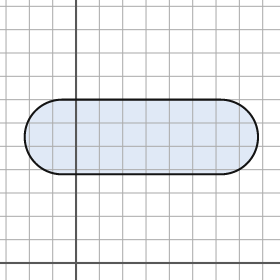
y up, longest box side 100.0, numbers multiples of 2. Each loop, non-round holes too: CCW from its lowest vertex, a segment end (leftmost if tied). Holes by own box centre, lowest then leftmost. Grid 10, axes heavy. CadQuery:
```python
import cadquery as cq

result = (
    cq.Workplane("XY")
    .moveTo(-6.0, 38.0)
    .lineTo(62.0, 38.0)
    .threePointArc((78.0, 54.0), (62.0, 70.0))
    .lineTo(-6.0, 70.0)
    .threePointArc((-22.0, 54.0), (-6.0, 38.0))
    .close()
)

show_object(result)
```